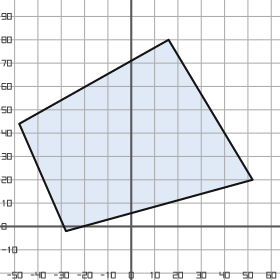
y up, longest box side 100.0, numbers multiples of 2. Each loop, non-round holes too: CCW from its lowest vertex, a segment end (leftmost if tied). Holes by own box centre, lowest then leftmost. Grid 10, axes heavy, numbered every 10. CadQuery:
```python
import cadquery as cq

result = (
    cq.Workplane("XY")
    .moveTo(-28.0, -2.0)
    .lineTo(52.0, 20.0)
    .lineTo(16.0, 80.0)
    .lineTo(-48.0, 44.0)
    .close()
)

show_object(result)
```